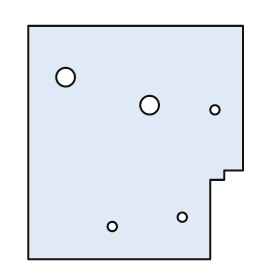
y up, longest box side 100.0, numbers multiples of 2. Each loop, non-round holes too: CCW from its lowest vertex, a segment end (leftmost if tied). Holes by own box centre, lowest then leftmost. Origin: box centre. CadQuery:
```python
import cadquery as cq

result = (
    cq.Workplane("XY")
    .moveTo(-46.0, -50.0)
    .lineTo(32.0, -50.0)
    .lineTo(32.0, -16.0)
    .lineTo(38.0, -16.0)
    .lineTo(38.0, -12.0)
    .lineTo(46.0, -12.0)
    .lineTo(46.0, 50.0)
    .lineTo(-46.0, 50.0)
    .close()
    .moveTo(-10.0, -36.0)
    .circle(2.0)
    .moveTo(20.0, -32.0)
    .circle(2.0)
    .moveTo(34.0, 14.0)
    .circle(2.0)
    .moveTo(6.0, 16.0)
    .circle(4.0)
    .moveTo(-30.0, 28.0)
    .circle(4.0)
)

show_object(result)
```